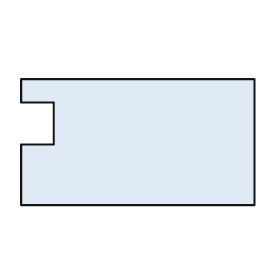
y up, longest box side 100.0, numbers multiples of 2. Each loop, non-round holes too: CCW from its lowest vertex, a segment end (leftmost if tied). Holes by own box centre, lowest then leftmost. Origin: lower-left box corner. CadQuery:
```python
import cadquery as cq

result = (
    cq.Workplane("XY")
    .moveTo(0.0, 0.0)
    .lineTo(100.0, 0.0)
    .lineTo(100.0, 54.0)
    .lineTo(0.0, 54.0)
    .lineTo(0.0, 44.0)
    .lineTo(14.0, 44.0)
    .lineTo(14.0, 26.0)
    .lineTo(0.0, 26.0)
    .close()
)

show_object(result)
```